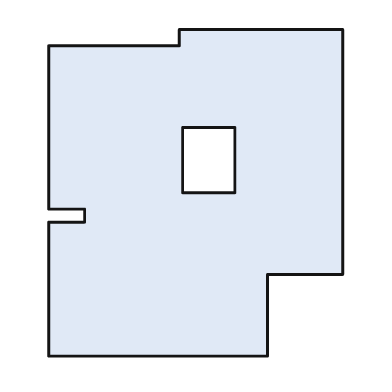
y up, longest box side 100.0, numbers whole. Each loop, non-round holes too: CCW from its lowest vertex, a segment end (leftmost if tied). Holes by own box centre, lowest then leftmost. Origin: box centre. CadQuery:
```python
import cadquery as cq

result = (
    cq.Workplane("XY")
    .moveTo(-45.0, -50.0)
    .lineTo(22.0, -50.0)
    .lineTo(22.0, -25.0)
    .lineTo(45.0, -25.0)
    .lineTo(45.0, 50.0)
    .lineTo(-5.0, 50.0)
    .lineTo(-5.0, 45.0)
    .lineTo(-45.0, 45.0)
    .lineTo(-45.0, -5.0)
    .lineTo(-34.0, -5.0)
    .lineTo(-34.0, -9.0)
    .lineTo(-45.0, -9.0)
    .close()
    .moveTo(-4.0, 0.0)
    .lineTo(12.0, 0.0)
    .lineTo(12.0, 20.0)
    .lineTo(-4.0, 20.0)
    .close()
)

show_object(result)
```